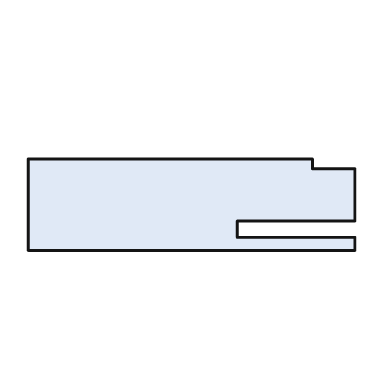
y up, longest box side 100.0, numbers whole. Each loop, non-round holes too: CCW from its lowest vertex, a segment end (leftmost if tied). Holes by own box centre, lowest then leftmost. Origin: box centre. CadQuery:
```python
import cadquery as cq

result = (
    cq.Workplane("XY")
    .moveTo(-50.0, -14.0)
    .lineTo(50.0, -14.0)
    .lineTo(50.0, -10.0)
    .lineTo(14.0, -10.0)
    .lineTo(14.0, -5.0)
    .lineTo(50.0, -5.0)
    .lineTo(50.0, 11.0)
    .lineTo(37.0, 11.0)
    .lineTo(37.0, 14.0)
    .lineTo(-50.0, 14.0)
    .close()
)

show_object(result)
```